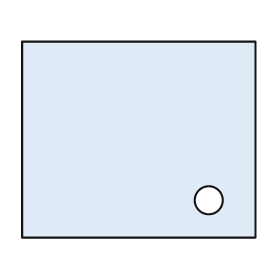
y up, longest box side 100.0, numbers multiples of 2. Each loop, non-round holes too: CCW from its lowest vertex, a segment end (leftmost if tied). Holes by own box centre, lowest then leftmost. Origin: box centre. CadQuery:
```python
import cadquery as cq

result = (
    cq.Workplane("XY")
    .moveTo(-50.0, -42.0)
    .lineTo(50.0, -42.0)
    .lineTo(50.0, 42.0)
    .lineTo(-50.0, 42.0)
    .close()
    .moveTo(30.0, -26.0)
    .circle(6.0)
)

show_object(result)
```